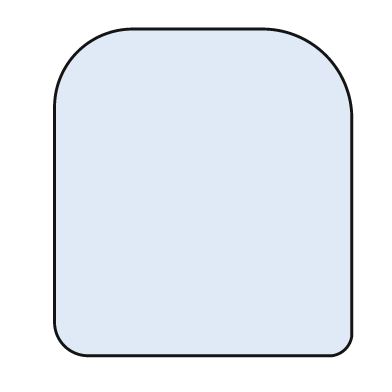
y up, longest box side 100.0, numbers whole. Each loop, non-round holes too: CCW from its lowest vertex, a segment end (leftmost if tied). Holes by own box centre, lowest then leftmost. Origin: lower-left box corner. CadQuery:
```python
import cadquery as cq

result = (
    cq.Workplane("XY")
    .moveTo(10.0, 0.0)
    .lineTo(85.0, 0.0)
    .threePointArc((89.0, 2.0), (91.0, 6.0))
    .lineTo(91.0, 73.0)
    .threePointArc((83.0, 92.0), (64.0, 100.0))
    .lineTo(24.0, 100.0)
    .threePointArc((7.0, 93.0), (0.0, 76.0))
    .lineTo(0.0, 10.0)
    .threePointArc((3.0, 3.0), (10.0, 0.0))
    .close()
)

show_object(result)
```